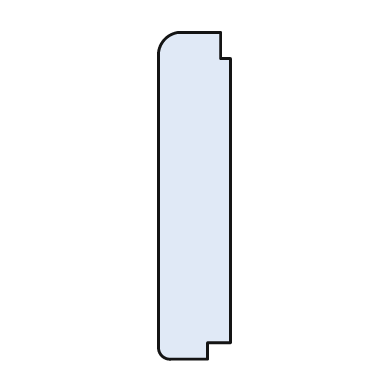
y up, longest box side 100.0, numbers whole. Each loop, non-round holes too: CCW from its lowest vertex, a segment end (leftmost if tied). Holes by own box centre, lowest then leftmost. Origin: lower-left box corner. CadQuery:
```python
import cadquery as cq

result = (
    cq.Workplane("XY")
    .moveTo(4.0, 0.0)
    .lineTo(15.0, 0.0)
    .lineTo(15.0, 5.0)
    .lineTo(22.0, 5.0)
    .lineTo(22.0, 92.0)
    .lineTo(19.0, 92.0)
    .lineTo(19.0, 100.0)
    .lineTo(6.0, 100.0)
    .threePointArc((2.0, 98.0), (0.0, 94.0))
    .lineTo(0.0, 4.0)
    .threePointArc((1.0, 1.0), (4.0, 0.0))
    .close()
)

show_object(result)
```